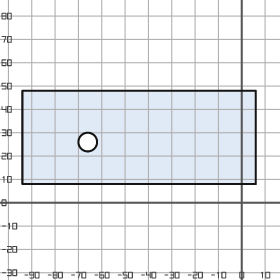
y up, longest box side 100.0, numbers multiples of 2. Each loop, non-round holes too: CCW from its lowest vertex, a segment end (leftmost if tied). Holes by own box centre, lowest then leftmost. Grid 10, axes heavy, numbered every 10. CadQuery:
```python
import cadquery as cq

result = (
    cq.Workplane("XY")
    .moveTo(-94.0, 8.0)
    .lineTo(6.0, 8.0)
    .lineTo(6.0, 48.0)
    .lineTo(-94.0, 48.0)
    .close()
    .moveTo(-66.0, 26.0)
    .circle(4.0)
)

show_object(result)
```